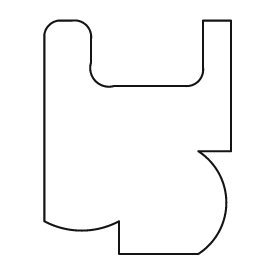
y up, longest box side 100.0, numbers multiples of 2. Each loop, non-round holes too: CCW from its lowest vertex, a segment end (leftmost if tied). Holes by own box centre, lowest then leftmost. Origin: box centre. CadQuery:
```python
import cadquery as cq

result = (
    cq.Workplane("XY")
    .moveTo(-8.0, -50.0)
    .lineTo(26.0, -50.0)
    .threePointArc((38.0, -28.0), (26.0, -6.0))
    .lineTo(40.0, -6.0)
    .lineTo(40.0, 50.0)
    .lineTo(28.0, 50.0)
    .lineTo(28.0, 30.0)
    .threePointArc((26.0, 24.0), (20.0, 22.0))
    .lineTo(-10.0, 22.0)
    .threePointArc((-18.0, 24.0), (-20.0, 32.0))
    .lineTo(-20.0, 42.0)
    .threePointArc((-22.0, 48.0), (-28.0, 50.0))
    .lineTo(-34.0, 50.0)
    .threePointArc((-38.0, 48.0), (-40.0, 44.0))
    .lineTo(-40.0, -36.0)
    .threePointArc((-24.0, -40.0), (-8.0, -36.0))
    .close()
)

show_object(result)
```